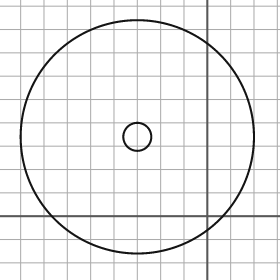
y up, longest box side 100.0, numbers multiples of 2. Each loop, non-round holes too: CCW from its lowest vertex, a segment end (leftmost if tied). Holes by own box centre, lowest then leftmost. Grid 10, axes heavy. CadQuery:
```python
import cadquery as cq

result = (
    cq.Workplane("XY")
    .moveTo(-30.0, 34.0)
    .circle(50.0)
    .moveTo(-30.0, 34.0)
    .circle(6.0)
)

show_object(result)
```